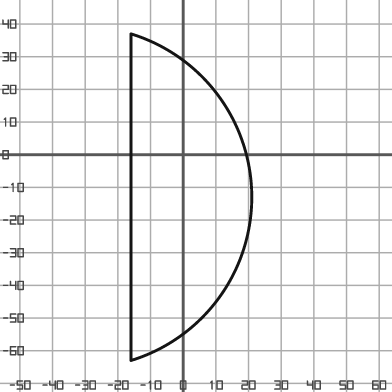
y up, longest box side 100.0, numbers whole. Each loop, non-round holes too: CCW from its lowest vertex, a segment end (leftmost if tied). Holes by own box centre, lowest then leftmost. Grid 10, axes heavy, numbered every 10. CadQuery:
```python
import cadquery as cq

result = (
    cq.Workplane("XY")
    .moveTo(-16.0, -63.0)
    .threePointArc((21.0, -13.0), (-16.0, 37.0))
    .close()
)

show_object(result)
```